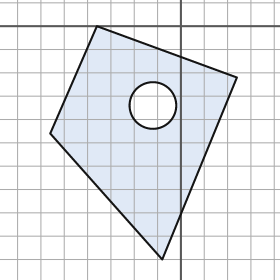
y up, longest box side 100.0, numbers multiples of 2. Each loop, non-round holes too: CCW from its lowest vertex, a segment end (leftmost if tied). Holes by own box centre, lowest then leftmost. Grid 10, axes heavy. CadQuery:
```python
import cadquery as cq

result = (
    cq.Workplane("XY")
    .moveTo(-8.0, -100.0)
    .lineTo(24.0, -22.0)
    .lineTo(-36.0, 0.0)
    .lineTo(-56.0, -46.0)
    .close()
    .moveTo(-12.0, -34.0)
    .circle(10.0)
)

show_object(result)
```